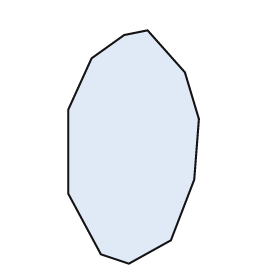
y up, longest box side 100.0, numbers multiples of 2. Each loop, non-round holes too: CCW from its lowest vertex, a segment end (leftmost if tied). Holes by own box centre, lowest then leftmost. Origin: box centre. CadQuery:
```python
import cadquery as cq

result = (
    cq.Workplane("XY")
    .moveTo(-2.0, -50.0)
    .lineTo(16.0, -40.0)
    .lineTo(26.0, -14.0)
    .lineTo(28.0, 12.0)
    .lineTo(22.0, 32.0)
    .lineTo(6.0, 50.0)
    .lineTo(-4.0, 48.0)
    .lineTo(-18.0, 38.0)
    .lineTo(-28.0, 16.0)
    .lineTo(-28.0, -20.0)
    .lineTo(-14.0, -46.0)
    .close()
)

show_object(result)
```